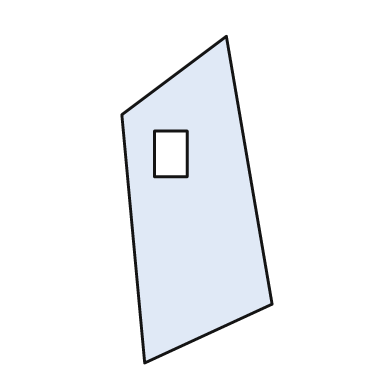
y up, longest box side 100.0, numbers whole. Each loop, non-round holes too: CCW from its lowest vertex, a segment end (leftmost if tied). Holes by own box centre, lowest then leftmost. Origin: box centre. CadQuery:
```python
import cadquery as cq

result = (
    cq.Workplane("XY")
    .moveTo(-16.0, -50.0)
    .lineTo(23.0, -32.0)
    .lineTo(9.0, 50.0)
    .lineTo(-23.0, 26.0)
    .close()
    .moveTo(-13.0, 7.0)
    .lineTo(-3.0, 7.0)
    .lineTo(-3.0, 21.0)
    .lineTo(-13.0, 21.0)
    .close()
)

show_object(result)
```